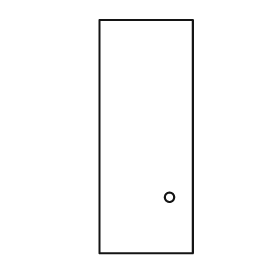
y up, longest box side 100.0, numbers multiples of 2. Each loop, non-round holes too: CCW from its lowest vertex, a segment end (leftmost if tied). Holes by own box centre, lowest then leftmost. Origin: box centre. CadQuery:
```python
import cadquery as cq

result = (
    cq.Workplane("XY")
    .moveTo(-20.0, -50.0)
    .lineTo(20.0, -50.0)
    .lineTo(20.0, 50.0)
    .lineTo(-20.0, 50.0)
    .close()
    .moveTo(10.0, -26.0)
    .circle(2.0)
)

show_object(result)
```